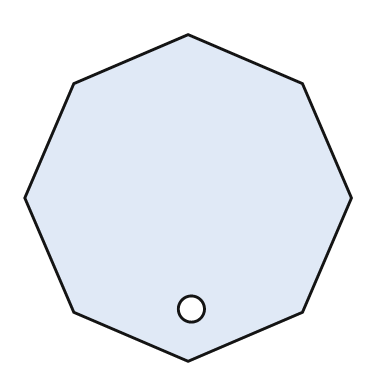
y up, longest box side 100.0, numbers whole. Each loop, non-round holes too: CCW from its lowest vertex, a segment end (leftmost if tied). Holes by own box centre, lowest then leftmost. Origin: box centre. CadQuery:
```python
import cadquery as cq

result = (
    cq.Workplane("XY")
    .moveTo(0.0, -50.0)
    .lineTo(35.0, -35.0)
    .lineTo(50.0, 0.0)
    .lineTo(35.0, 35.0)
    .lineTo(0.0, 50.0)
    .lineTo(-35.0, 35.0)
    .lineTo(-50.0, 0.0)
    .lineTo(-35.0, -35.0)
    .close()
    .moveTo(1.0, -34.0)
    .circle(4.0)
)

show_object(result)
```